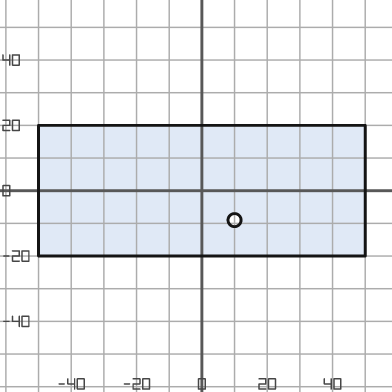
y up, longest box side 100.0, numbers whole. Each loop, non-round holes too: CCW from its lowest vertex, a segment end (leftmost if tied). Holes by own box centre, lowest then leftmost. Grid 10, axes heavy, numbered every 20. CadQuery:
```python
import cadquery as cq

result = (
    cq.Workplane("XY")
    .moveTo(-50.0, -20.0)
    .lineTo(50.0, -20.0)
    .lineTo(50.0, 20.0)
    .lineTo(-50.0, 20.0)
    .close()
    .moveTo(10.0, -9.0)
    .circle(2.0)
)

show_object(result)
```